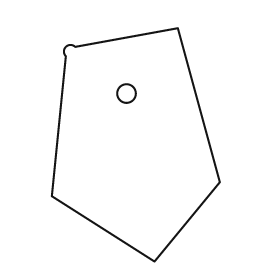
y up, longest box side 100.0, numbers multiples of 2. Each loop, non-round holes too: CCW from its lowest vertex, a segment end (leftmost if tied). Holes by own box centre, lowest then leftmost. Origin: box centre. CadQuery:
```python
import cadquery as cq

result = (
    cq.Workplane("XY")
    .moveTo(8.0, -50.0)
    .lineTo(36.0, -16.0)
    .lineTo(18.0, 50.0)
    .lineTo(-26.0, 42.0)
    .threePointArc((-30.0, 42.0), (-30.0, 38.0))
    .lineTo(-36.0, -22.0)
    .close()
    .moveTo(-4.0, 22.0)
    .circle(4.0)
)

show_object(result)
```